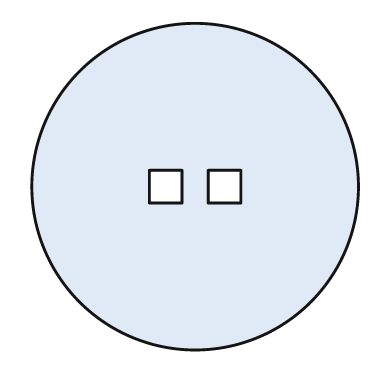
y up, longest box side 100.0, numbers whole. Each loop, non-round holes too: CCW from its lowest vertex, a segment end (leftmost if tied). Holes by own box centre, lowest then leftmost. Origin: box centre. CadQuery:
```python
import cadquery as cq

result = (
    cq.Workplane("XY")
    .moveTo(0.0, 0.0)
    .circle(50.0)
    .moveTo(-14.0, -5.0)
    .lineTo(-4.0, -5.0)
    .lineTo(-4.0, 5.0)
    .lineTo(-14.0, 5.0)
    .close()
    .moveTo(4.0, -5.0)
    .lineTo(14.0, -5.0)
    .lineTo(14.0, 5.0)
    .lineTo(4.0, 5.0)
    .close()
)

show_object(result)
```